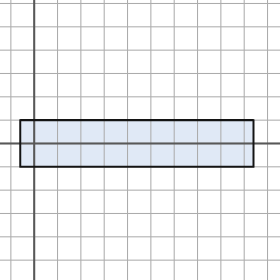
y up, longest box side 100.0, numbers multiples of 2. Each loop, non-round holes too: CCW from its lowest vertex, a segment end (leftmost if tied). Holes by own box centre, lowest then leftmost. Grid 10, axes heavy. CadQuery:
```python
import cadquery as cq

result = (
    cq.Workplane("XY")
    .moveTo(-6.0, -10.0)
    .lineTo(94.0, -10.0)
    .lineTo(94.0, 10.0)
    .lineTo(-6.0, 10.0)
    .close()
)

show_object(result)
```